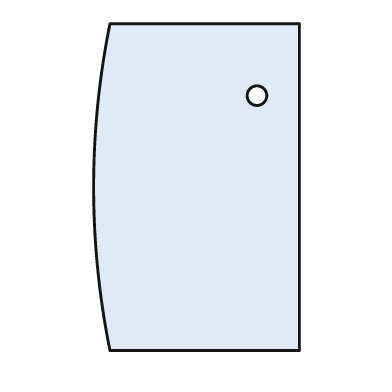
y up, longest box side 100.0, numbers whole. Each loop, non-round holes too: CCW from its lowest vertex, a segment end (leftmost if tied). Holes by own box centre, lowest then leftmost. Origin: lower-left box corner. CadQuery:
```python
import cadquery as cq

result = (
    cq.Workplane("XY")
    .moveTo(5.0, 0.0)
    .lineTo(63.0, 0.0)
    .lineTo(63.0, 100.0)
    .lineTo(5.0, 100.0)
    .threePointArc((0.0, 50.0), (5.0, 0.0))
    .close()
    .moveTo(50.0, 78.0)
    .circle(3.0)
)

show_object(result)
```